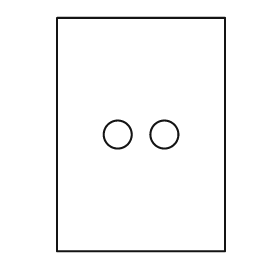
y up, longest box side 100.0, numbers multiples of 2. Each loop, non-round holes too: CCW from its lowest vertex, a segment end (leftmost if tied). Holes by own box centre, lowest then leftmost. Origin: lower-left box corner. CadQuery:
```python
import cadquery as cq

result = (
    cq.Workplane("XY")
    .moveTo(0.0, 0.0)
    .lineTo(72.0, 0.0)
    .lineTo(72.0, 100.0)
    .lineTo(0.0, 100.0)
    .close()
    .moveTo(26.0, 50.0)
    .circle(6.0)
    .moveTo(46.0, 50.0)
    .circle(6.0)
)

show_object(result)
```